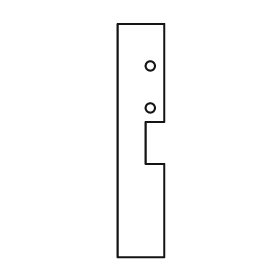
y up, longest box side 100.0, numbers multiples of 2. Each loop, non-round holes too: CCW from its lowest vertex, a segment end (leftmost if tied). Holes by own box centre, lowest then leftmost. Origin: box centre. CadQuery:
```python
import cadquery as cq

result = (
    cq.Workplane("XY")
    .moveTo(-10.0, -50.0)
    .lineTo(10.0, -50.0)
    .lineTo(10.0, -10.0)
    .lineTo(2.0, -10.0)
    .lineTo(2.0, 8.0)
    .lineTo(10.0, 8.0)
    .lineTo(10.0, 50.0)
    .lineTo(-10.0, 50.0)
    .close()
    .moveTo(4.0, 14.0)
    .circle(2.0)
    .moveTo(4.0, 32.0)
    .circle(2.0)
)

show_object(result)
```